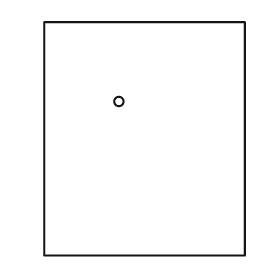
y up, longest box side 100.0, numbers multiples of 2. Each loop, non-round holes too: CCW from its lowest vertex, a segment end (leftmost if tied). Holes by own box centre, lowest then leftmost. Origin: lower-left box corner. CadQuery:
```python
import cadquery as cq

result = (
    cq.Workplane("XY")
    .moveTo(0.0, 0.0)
    .lineTo(86.0, 0.0)
    .lineTo(86.0, 100.0)
    .lineTo(0.0, 100.0)
    .close()
    .moveTo(32.0, 66.0)
    .circle(2.0)
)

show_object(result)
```